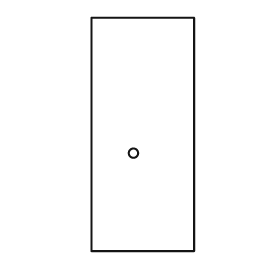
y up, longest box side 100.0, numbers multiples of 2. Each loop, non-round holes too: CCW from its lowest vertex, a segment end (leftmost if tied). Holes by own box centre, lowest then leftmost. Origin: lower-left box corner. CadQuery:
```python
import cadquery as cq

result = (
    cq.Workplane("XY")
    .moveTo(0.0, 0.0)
    .lineTo(44.0, 0.0)
    .lineTo(44.0, 100.0)
    .lineTo(0.0, 100.0)
    .close()
    .moveTo(18.0, 42.0)
    .circle(2.0)
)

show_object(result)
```